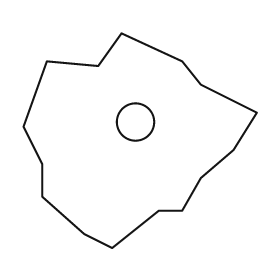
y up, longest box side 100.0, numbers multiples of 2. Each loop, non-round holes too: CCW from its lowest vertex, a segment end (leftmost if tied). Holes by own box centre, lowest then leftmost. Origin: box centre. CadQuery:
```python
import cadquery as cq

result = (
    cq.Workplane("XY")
    .moveTo(-12.0, -46.0)
    .lineTo(8.0, -30.0)
    .lineTo(18.0, -30.0)
    .lineTo(26.0, -16.0)
    .lineTo(40.0, -4.0)
    .lineTo(50.0, 12.0)
    .lineTo(26.0, 24.0)
    .lineTo(18.0, 34.0)
    .lineTo(-8.0, 46.0)
    .lineTo(-18.0, 32.0)
    .lineTo(-40.0, 34.0)
    .lineTo(-50.0, 6.0)
    .lineTo(-42.0, -10.0)
    .lineTo(-42.0, -24.0)
    .lineTo(-24.0, -40.0)
    .close()
    .moveTo(-2.0, 8.0)
    .circle(8.0)
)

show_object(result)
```